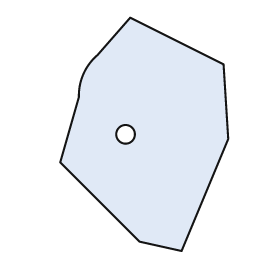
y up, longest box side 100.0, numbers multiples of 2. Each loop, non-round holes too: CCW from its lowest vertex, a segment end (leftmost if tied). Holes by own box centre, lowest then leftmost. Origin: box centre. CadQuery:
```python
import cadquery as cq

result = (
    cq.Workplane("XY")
    .moveTo(16.0, -50.0)
    .lineTo(36.0, -2.0)
    .lineTo(34.0, 30.0)
    .lineTo(-6.0, 50.0)
    .lineTo(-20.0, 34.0)
    .threePointArc((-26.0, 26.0), (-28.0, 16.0))
    .lineTo(-36.0, -12.0)
    .lineTo(-2.0, -46.0)
    .close()
    .moveTo(-8.0, 0.0)
    .circle(4.0)
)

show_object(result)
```